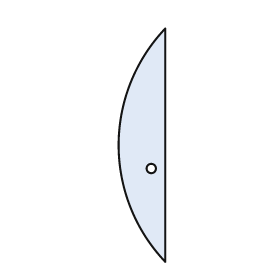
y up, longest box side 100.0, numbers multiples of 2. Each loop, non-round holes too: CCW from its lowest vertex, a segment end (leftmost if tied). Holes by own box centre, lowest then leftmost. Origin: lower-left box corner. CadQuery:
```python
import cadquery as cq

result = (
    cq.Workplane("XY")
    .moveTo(20.0, 0.0)
    .lineTo(20.0, 100.0)
    .threePointArc((0.0, 50.0), (20.0, 0.0))
    .close()
    .moveTo(14.0, 40.0)
    .circle(2.0)
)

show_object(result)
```